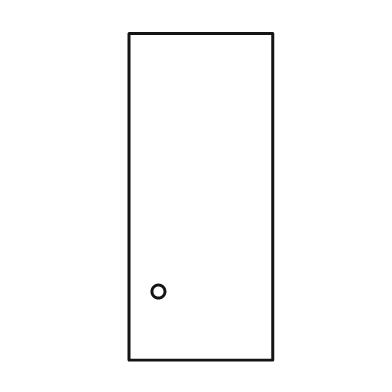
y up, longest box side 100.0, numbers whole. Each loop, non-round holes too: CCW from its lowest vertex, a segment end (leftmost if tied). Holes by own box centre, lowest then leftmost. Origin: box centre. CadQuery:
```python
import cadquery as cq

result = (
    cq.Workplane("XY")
    .moveTo(-22.0, -50.0)
    .lineTo(22.0, -50.0)
    .lineTo(22.0, 50.0)
    .lineTo(-22.0, 50.0)
    .close()
    .moveTo(-13.0, -29.0)
    .circle(2.0)
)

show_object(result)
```